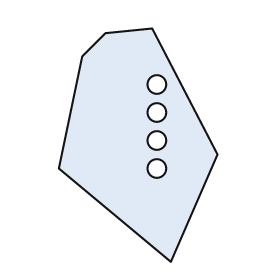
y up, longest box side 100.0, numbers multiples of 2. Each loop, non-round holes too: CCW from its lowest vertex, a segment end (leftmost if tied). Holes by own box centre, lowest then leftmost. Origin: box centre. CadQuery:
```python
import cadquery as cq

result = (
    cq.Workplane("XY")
    .moveTo(14.0, -50.0)
    .lineTo(34.0, -4.0)
    .lineTo(6.0, 50.0)
    .lineTo(-14.0, 48.0)
    .lineTo(-24.0, 38.0)
    .lineTo(-34.0, -10.0)
    .close()
    .moveTo(8.0, -10.0)
    .circle(4.0)
    .moveTo(8.0, 2.0)
    .circle(4.0)
    .moveTo(8.0, 14.0)
    .circle(4.0)
    .moveTo(8.0, 26.0)
    .circle(4.0)
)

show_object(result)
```